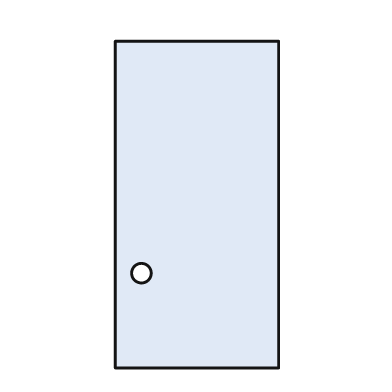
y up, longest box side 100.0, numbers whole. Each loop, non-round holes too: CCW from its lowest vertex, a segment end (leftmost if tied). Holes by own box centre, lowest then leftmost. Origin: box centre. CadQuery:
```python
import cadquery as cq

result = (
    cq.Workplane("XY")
    .moveTo(-25.0, -50.0)
    .lineTo(25.0, -50.0)
    .lineTo(25.0, 50.0)
    .lineTo(-25.0, 50.0)
    .close()
    .moveTo(-17.0, -21.0)
    .circle(3.0)
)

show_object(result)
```